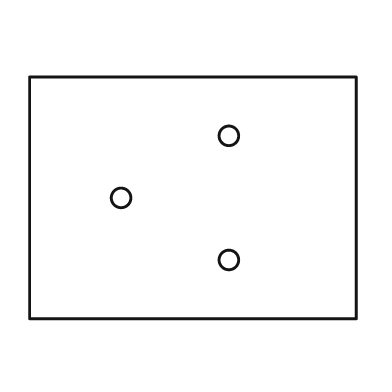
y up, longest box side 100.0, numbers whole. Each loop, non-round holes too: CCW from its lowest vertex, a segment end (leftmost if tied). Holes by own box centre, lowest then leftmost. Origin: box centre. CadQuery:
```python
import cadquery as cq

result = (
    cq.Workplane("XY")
    .moveTo(-50.0, -37.0)
    .lineTo(50.0, -37.0)
    .lineTo(50.0, 37.0)
    .lineTo(-50.0, 37.0)
    .close()
    .moveTo(11.0, -19.0)
    .circle(3.0)
    .moveTo(-22.0, 0.0)
    .circle(3.0)
    .moveTo(11.0, 19.0)
    .circle(3.0)
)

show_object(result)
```